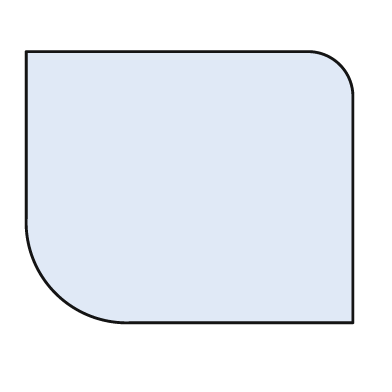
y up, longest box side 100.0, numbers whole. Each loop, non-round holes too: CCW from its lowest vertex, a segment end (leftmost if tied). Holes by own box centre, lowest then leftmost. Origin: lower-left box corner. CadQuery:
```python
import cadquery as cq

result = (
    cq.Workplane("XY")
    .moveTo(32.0, 0.0)
    .lineTo(100.0, 0.0)
    .lineTo(100.0, 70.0)
    .threePointArc((96.0, 79.0), (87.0, 83.0))
    .lineTo(0.0, 83.0)
    .lineTo(0.0, 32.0)
    .threePointArc((9.0, 9.0), (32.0, 0.0))
    .close()
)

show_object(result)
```